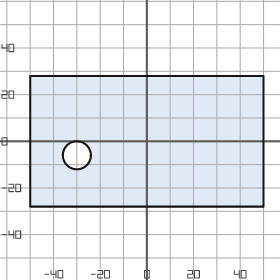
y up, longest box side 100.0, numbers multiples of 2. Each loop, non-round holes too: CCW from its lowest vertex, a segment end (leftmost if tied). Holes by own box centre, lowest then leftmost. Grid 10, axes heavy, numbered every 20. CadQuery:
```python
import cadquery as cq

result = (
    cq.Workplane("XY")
    .moveTo(-50.0, -28.0)
    .lineTo(50.0, -28.0)
    .lineTo(50.0, 28.0)
    .lineTo(-50.0, 28.0)
    .close()
    .moveTo(-30.0, -6.0)
    .circle(6.0)
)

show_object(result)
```